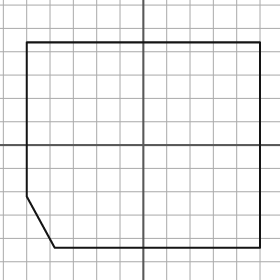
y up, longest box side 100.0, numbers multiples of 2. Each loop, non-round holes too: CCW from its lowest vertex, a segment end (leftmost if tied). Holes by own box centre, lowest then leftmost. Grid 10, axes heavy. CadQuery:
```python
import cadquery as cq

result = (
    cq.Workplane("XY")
    .moveTo(-38.0, -44.0)
    .lineTo(50.0, -44.0)
    .lineTo(50.0, 44.0)
    .lineTo(-50.0, 44.0)
    .lineTo(-50.0, -22.0)
    .close()
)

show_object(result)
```